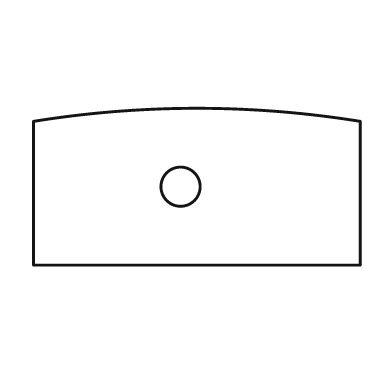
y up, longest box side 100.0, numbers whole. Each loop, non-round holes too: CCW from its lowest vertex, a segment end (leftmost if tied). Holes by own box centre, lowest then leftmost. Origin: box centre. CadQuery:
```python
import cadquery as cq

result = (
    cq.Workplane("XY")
    .moveTo(-50.0, -24.0)
    .lineTo(50.0, -24.0)
    .lineTo(50.0, 20.0)
    .threePointArc((0.0, 24.0), (-50.0, 20.0))
    .close()
    .moveTo(-5.0, 0.0)
    .circle(6.0)
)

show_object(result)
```